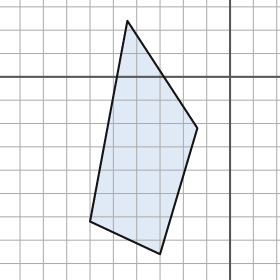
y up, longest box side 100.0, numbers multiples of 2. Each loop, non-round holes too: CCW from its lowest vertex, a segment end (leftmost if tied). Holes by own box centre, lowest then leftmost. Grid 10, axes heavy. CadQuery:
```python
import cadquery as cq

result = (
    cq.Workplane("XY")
    .moveTo(-30.0, -76.0)
    .lineTo(-14.0, -22.0)
    .lineTo(-44.0, 24.0)
    .lineTo(-60.0, -62.0)
    .close()
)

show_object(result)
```